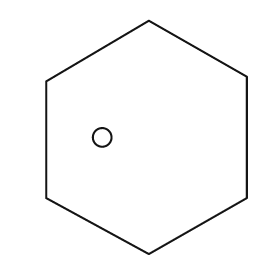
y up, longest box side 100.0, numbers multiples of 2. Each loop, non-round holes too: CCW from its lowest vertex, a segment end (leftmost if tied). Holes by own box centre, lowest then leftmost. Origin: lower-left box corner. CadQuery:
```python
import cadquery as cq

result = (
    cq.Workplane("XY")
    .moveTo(44.0, 0.0)
    .lineTo(86.0, 24.0)
    .lineTo(86.0, 76.0)
    .lineTo(44.0, 100.0)
    .lineTo(0.0, 74.0)
    .lineTo(0.0, 24.0)
    .close()
    .moveTo(24.0, 50.0)
    .circle(4.0)
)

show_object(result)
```